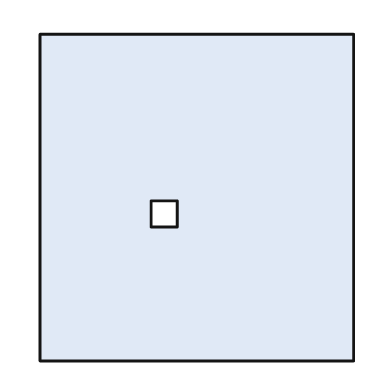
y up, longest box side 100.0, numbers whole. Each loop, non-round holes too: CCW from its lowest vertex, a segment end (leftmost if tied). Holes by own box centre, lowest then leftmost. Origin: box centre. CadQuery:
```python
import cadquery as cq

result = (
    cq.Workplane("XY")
    .moveTo(-48.0, -50.0)
    .lineTo(48.0, -50.0)
    .lineTo(48.0, 50.0)
    .lineTo(-48.0, 50.0)
    .close()
    .moveTo(-14.0, -9.0)
    .lineTo(-6.0, -9.0)
    .lineTo(-6.0, -1.0)
    .lineTo(-14.0, -1.0)
    .close()
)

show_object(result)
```